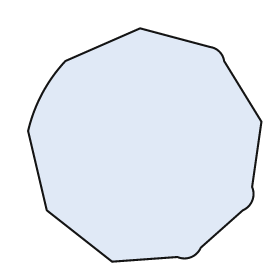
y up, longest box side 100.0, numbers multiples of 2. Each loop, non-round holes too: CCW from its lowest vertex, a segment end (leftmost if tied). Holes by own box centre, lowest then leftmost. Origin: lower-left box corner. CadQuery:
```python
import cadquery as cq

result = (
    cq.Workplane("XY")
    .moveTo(36.0, 0.0)
    .lineTo(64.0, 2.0)
    .threePointArc((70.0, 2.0), (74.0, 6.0))
    .lineTo(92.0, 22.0)
    .threePointArc((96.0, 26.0), (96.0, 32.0))
    .lineTo(100.0, 60.0)
    .lineTo(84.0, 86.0)
    .threePointArc((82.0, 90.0), (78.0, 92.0))
    .lineTo(48.0, 100.0)
    .lineTo(16.0, 86.0)
    .threePointArc((6.0, 72.0), (0.0, 56.0))
    .lineTo(8.0, 22.0)
    .close()
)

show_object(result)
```